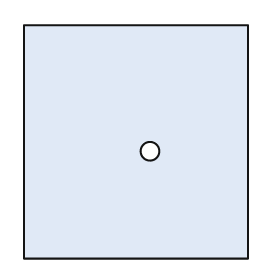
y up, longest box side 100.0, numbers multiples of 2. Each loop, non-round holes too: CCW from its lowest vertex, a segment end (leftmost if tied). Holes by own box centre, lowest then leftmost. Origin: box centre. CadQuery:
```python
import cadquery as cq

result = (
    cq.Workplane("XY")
    .moveTo(-48.0, -50.0)
    .lineTo(48.0, -50.0)
    .lineTo(48.0, 50.0)
    .lineTo(-48.0, 50.0)
    .close()
    .moveTo(6.0, -4.0)
    .circle(4.0)
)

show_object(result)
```